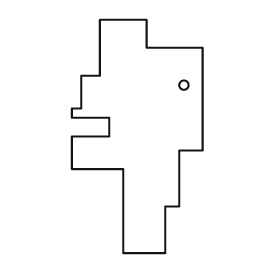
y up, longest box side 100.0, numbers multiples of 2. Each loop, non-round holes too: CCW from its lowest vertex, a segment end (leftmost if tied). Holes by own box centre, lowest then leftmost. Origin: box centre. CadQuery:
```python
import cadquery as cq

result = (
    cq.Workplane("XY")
    .moveTo(-6.0, -50.0)
    .lineTo(12.0, -50.0)
    .lineTo(12.0, -30.0)
    .lineTo(18.0, -30.0)
    .lineTo(18.0, -6.0)
    .lineTo(28.0, -6.0)
    .lineTo(28.0, 38.0)
    .lineTo(4.0, 38.0)
    .lineTo(4.0, 50.0)
    .lineTo(-16.0, 50.0)
    .lineTo(-16.0, 26.0)
    .lineTo(-24.0, 26.0)
    .lineTo(-24.0, 12.0)
    .lineTo(-28.0, 12.0)
    .lineTo(-28.0, 8.0)
    .lineTo(-12.0, 8.0)
    .lineTo(-12.0, 0.0)
    .lineTo(-28.0, 0.0)
    .lineTo(-28.0, -14.0)
    .lineTo(-6.0, -14.0)
    .close()
    .moveTo(20.0, 22.0)
    .circle(2.0)
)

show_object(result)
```